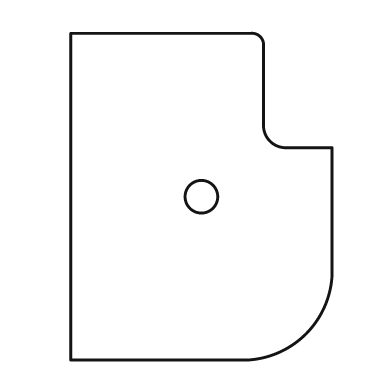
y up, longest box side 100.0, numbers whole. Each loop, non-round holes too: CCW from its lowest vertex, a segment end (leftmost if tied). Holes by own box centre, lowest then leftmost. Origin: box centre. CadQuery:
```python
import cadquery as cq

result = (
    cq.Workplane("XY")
    .moveTo(-40.0, -50.0)
    .lineTo(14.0, -50.0)
    .threePointArc((32.0, -42.0), (40.0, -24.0))
    .lineTo(40.0, 15.0)
    .lineTo(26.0, 15.0)
    .threePointArc((21.0, 17.0), (19.0, 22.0))
    .lineTo(19.0, 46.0)
    .threePointArc((18.0, 49.0), (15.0, 50.0))
    .lineTo(-40.0, 50.0)
    .close()
    .moveTo(0.0, 0.0)
    .circle(5.0)
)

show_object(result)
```